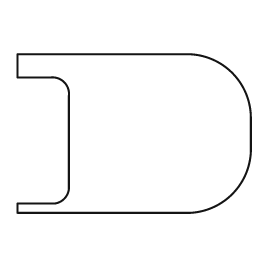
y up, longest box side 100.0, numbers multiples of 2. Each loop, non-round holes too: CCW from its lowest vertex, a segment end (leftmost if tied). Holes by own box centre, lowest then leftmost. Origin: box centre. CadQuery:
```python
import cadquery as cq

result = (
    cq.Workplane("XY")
    .moveTo(-50.0, -34.0)
    .lineTo(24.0, -34.0)
    .threePointArc((42.0, -26.0), (50.0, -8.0))
    .lineTo(50.0, 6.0)
    .threePointArc((42.0, 26.0), (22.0, 34.0))
    .lineTo(-50.0, 34.0)
    .lineTo(-50.0, 24.0)
    .lineTo(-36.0, 24.0)
    .threePointArc((-30.0, 22.0), (-28.0, 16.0))
    .lineTo(-28.0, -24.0)
    .threePointArc((-30.0, -28.0), (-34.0, -30.0))
    .lineTo(-50.0, -30.0)
    .close()
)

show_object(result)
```